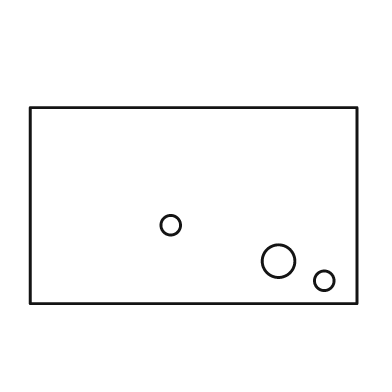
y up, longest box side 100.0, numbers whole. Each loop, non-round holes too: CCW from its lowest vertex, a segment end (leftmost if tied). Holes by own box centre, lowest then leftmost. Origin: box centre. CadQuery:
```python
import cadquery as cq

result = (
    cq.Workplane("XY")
    .moveTo(-50.0, -30.0)
    .lineTo(50.0, -30.0)
    .lineTo(50.0, 30.0)
    .lineTo(-50.0, 30.0)
    .close()
    .moveTo(40.0, -23.0)
    .circle(3.0)
    .moveTo(26.0, -17.0)
    .circle(5.0)
    .moveTo(-7.0, -6.0)
    .circle(3.0)
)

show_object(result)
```